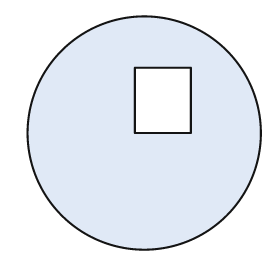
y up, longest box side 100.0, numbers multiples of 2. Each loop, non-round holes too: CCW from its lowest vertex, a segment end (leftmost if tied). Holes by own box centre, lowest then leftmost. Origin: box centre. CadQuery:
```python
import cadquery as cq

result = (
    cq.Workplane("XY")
    .moveTo(0.0, 0.0)
    .circle(50.0)
    .moveTo(-4.0, 0.0)
    .lineTo(20.0, 0.0)
    .lineTo(20.0, 28.0)
    .lineTo(-4.0, 28.0)
    .close()
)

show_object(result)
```